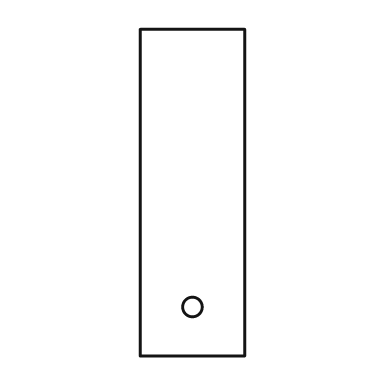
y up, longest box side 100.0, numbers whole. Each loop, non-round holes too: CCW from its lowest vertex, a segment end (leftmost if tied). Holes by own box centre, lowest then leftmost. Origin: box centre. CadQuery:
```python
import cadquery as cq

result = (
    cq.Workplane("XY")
    .moveTo(-16.0, -50.0)
    .lineTo(16.0, -50.0)
    .lineTo(16.0, 50.0)
    .lineTo(-16.0, 50.0)
    .close()
    .moveTo(0.0, -35.0)
    .circle(3.0)
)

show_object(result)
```